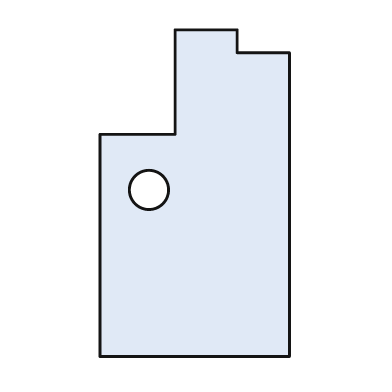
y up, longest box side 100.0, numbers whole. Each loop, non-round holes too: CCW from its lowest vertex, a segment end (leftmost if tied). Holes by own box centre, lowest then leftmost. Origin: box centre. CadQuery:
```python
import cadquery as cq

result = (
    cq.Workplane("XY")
    .moveTo(-29.0, -50.0)
    .lineTo(29.0, -50.0)
    .lineTo(29.0, 43.0)
    .lineTo(13.0, 43.0)
    .lineTo(13.0, 50.0)
    .lineTo(-6.0, 50.0)
    .lineTo(-6.0, 18.0)
    .lineTo(-29.0, 18.0)
    .close()
    .moveTo(-14.0, 1.0)
    .circle(6.0)
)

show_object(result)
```